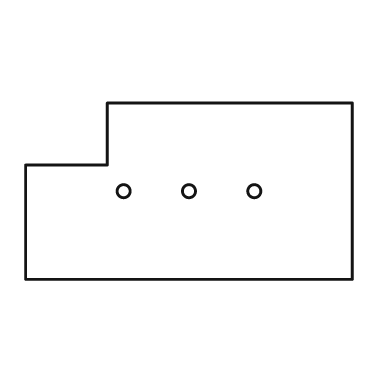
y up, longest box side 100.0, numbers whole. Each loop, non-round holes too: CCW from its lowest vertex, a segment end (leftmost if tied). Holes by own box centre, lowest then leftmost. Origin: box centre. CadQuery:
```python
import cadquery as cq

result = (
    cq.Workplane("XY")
    .moveTo(-50.0, -27.0)
    .lineTo(50.0, -27.0)
    .lineTo(50.0, 27.0)
    .lineTo(-25.0, 27.0)
    .lineTo(-25.0, 8.0)
    .lineTo(-50.0, 8.0)
    .close()
    .moveTo(-20.0, 0.0)
    .circle(2.0)
    .moveTo(0.0, 0.0)
    .circle(2.0)
    .moveTo(20.0, 0.0)
    .circle(2.0)
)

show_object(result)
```